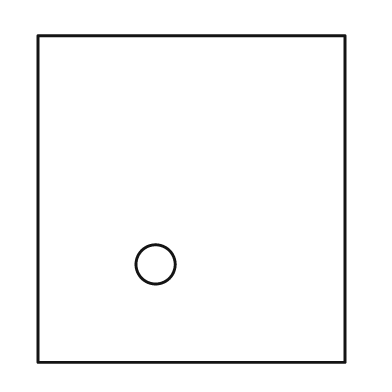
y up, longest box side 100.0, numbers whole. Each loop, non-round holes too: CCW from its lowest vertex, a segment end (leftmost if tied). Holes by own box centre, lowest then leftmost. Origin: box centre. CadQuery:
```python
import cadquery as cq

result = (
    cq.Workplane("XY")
    .moveTo(-47.0, -50.0)
    .lineTo(47.0, -50.0)
    .lineTo(47.0, 50.0)
    .lineTo(-47.0, 50.0)
    .close()
    .moveTo(-11.0, -20.0)
    .circle(6.0)
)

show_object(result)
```